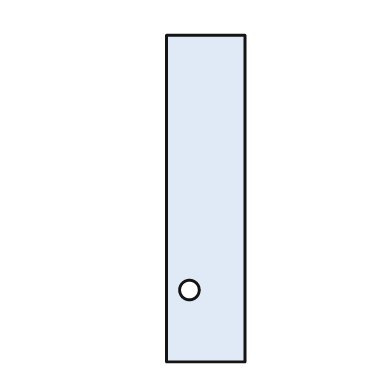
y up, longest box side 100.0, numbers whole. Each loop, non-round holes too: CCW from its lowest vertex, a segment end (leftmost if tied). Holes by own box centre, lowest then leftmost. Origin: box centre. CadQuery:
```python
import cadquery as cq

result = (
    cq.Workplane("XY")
    .moveTo(-12.0, -50.0)
    .lineTo(12.0, -50.0)
    .lineTo(12.0, 50.0)
    .lineTo(-12.0, 50.0)
    .close()
    .moveTo(-5.0, -28.0)
    .circle(3.0)
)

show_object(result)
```